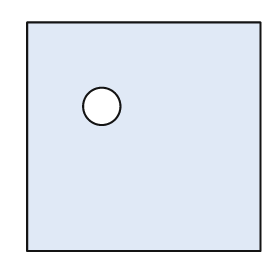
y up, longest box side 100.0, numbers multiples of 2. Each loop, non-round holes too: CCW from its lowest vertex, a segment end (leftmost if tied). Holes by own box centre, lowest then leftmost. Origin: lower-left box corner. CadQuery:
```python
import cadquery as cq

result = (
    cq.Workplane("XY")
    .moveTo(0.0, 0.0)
    .lineTo(100.0, 0.0)
    .lineTo(100.0, 98.0)
    .lineTo(0.0, 98.0)
    .close()
    .moveTo(32.0, 62.0)
    .circle(8.0)
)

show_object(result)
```